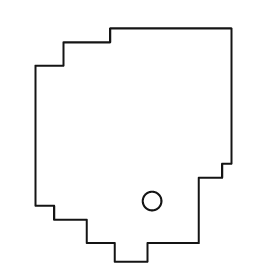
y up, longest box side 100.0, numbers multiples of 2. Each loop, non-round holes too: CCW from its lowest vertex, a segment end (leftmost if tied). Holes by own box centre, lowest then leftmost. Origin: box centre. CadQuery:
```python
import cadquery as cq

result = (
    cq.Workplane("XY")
    .moveTo(-8.0, -50.0)
    .lineTo(6.0, -50.0)
    .lineTo(6.0, -42.0)
    .lineTo(28.0, -42.0)
    .lineTo(28.0, -14.0)
    .lineTo(38.0, -14.0)
    .lineTo(38.0, -8.0)
    .lineTo(42.0, -8.0)
    .lineTo(42.0, 50.0)
    .lineTo(-10.0, 50.0)
    .lineTo(-10.0, 44.0)
    .lineTo(-30.0, 44.0)
    .lineTo(-30.0, 34.0)
    .lineTo(-42.0, 34.0)
    .lineTo(-42.0, -26.0)
    .lineTo(-34.0, -26.0)
    .lineTo(-34.0, -32.0)
    .lineTo(-20.0, -32.0)
    .lineTo(-20.0, -42.0)
    .lineTo(-8.0, -42.0)
    .close()
    .moveTo(8.0, -24.0)
    .circle(4.0)
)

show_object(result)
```